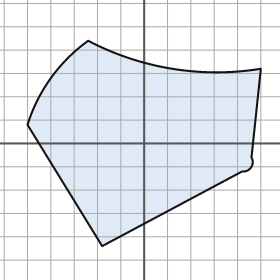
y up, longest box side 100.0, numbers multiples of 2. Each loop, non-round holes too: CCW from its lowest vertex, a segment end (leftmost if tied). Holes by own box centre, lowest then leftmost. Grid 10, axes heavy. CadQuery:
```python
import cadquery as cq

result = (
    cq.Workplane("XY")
    .moveTo(-18.0, -44.0)
    .lineTo(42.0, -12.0)
    .threePointArc((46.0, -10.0), (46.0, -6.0))
    .lineTo(50.0, 32.0)
    .threePointArc((12.0, 32.0), (-24.0, 44.0))
    .threePointArc((-40.0, 28.0), (-50.0, 8.0))
    .close()
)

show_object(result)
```